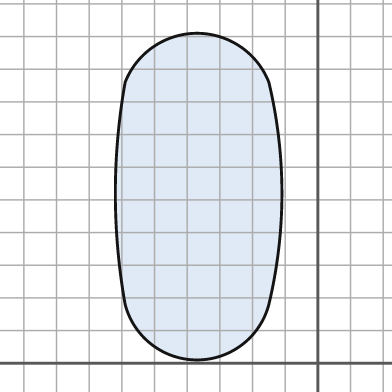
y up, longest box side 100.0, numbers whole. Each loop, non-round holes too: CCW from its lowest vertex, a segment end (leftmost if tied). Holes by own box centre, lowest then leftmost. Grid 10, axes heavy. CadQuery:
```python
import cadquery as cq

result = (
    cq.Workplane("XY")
    .moveTo(-59.0, 18.0)
    .threePointArc((-37.0, 1.0), (-15.0, 18.0))
    .threePointArc((-11.0, 52.0), (-15.0, 86.0))
    .threePointArc((-37.0, 101.0), (-59.0, 86.0))
    .threePointArc((-62.0, 52.0), (-59.0, 18.0))
    .close()
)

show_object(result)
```